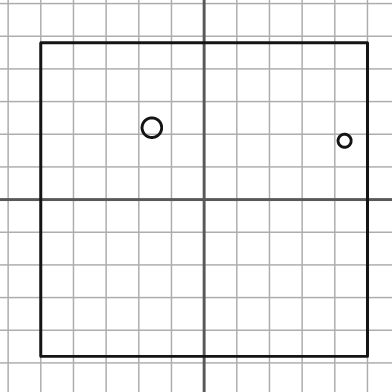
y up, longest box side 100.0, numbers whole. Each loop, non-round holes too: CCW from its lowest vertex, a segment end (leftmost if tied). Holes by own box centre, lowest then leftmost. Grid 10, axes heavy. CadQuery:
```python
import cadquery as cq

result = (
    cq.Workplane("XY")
    .moveTo(-50.0, -48.0)
    .lineTo(50.0, -48.0)
    .lineTo(50.0, 48.0)
    .lineTo(-50.0, 48.0)
    .close()
    .moveTo(43.0, 18.0)
    .circle(2.0)
    .moveTo(-16.0, 22.0)
    .circle(3.0)
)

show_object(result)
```